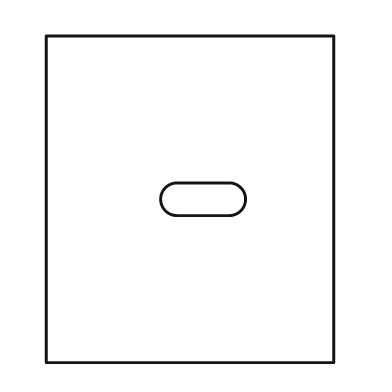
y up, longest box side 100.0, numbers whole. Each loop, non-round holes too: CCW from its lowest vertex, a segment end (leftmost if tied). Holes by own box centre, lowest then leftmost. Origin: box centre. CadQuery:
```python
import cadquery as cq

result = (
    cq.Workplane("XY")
    .moveTo(-44.0, -50.0)
    .lineTo(44.0, -50.0)
    .lineTo(44.0, 50.0)
    .lineTo(-44.0, 50.0)
    .close()
    .moveTo(-4.0, -5.0)
    .lineTo(12.0, -5.0)
    .threePointArc((17.0, 0.0), (12.0, 5.0))
    .lineTo(-4.0, 5.0)
    .threePointArc((-9.0, 0.0), (-4.0, -5.0))
    .close()
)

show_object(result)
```